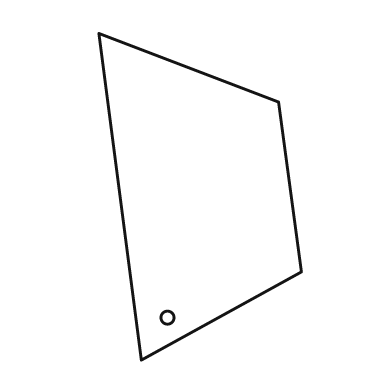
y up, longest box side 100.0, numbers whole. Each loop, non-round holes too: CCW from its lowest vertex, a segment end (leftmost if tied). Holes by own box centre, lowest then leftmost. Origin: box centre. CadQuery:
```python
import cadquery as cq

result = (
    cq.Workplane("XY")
    .moveTo(-18.0, -50.0)
    .lineTo(31.0, -23.0)
    .lineTo(24.0, 29.0)
    .lineTo(-31.0, 50.0)
    .close()
    .moveTo(-10.0, -37.0)
    .circle(2.0)
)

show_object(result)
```